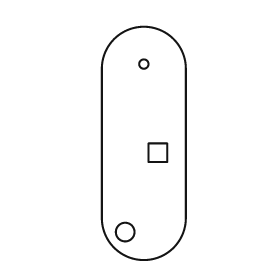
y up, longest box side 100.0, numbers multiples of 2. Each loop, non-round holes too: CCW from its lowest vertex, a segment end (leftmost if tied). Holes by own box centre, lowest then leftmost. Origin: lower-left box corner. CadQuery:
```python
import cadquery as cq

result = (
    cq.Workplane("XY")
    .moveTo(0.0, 18.0)
    .threePointArc((18.0, 0.0), (36.0, 18.0))
    .lineTo(36.0, 82.0)
    .threePointArc((18.0, 100.0), (0.0, 82.0))
    .close()
    .moveTo(10.0, 12.0)
    .circle(4.0)
    .moveTo(20.0, 42.0)
    .lineTo(28.0, 42.0)
    .lineTo(28.0, 50.0)
    .lineTo(20.0, 50.0)
    .close()
    .moveTo(18.0, 84.0)
    .circle(2.0)
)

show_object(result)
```